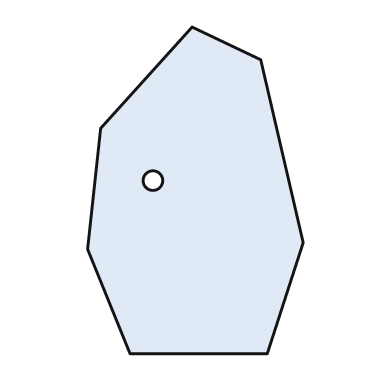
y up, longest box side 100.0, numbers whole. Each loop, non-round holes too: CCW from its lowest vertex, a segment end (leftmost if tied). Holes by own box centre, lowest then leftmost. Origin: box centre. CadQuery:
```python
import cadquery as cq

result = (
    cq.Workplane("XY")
    .moveTo(-20.0, -50.0)
    .lineTo(22.0, -50.0)
    .lineTo(33.0, -16.0)
    .lineTo(20.0, 40.0)
    .lineTo(-1.0, 50.0)
    .lineTo(-29.0, 19.0)
    .lineTo(-33.0, -18.0)
    .close()
    .moveTo(-13.0, 3.0)
    .circle(3.0)
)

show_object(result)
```